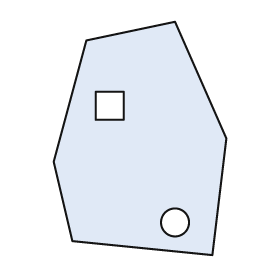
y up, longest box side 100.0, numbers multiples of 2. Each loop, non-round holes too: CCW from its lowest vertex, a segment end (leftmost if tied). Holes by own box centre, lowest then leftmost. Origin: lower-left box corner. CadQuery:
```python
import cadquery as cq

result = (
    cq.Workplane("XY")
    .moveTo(68.0, 0.0)
    .lineTo(74.0, 50.0)
    .lineTo(52.0, 100.0)
    .lineTo(14.0, 92.0)
    .lineTo(0.0, 40.0)
    .lineTo(8.0, 6.0)
    .close()
    .moveTo(52.0, 14.0)
    .circle(6.0)
    .moveTo(18.0, 58.0)
    .lineTo(30.0, 58.0)
    .lineTo(30.0, 70.0)
    .lineTo(18.0, 70.0)
    .close()
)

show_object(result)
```